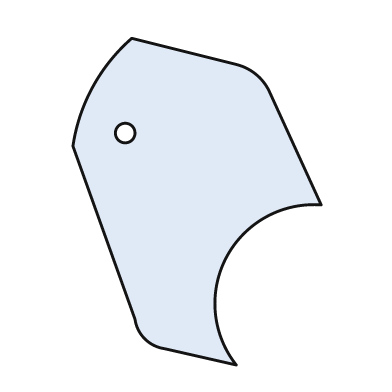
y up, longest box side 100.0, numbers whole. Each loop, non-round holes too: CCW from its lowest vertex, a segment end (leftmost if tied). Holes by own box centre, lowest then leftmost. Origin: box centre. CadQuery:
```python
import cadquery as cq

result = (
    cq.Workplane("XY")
    .moveTo(12.0, -50.0)
    .threePointArc((9.0, -17.0), (38.0, -1.0))
    .lineTo(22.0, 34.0)
    .threePointArc((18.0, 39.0), (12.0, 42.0))
    .lineTo(-20.0, 50.0)
    .threePointArc((-32.0, 35.0), (-38.0, 17.0))
    .lineTo(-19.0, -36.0)
    .threePointArc((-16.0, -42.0), (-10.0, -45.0))
    .close()
    .moveTo(-22.0, 21.0)
    .circle(3.0)
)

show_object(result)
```